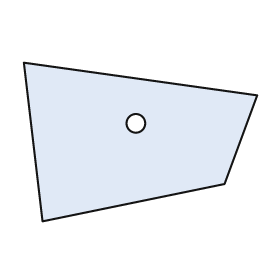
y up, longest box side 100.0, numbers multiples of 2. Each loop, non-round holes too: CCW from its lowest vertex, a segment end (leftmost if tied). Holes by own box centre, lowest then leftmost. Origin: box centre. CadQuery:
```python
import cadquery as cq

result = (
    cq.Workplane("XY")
    .moveTo(-42.0, -34.0)
    .lineTo(36.0, -18.0)
    .lineTo(50.0, 20.0)
    .lineTo(-50.0, 34.0)
    .close()
    .moveTo(-2.0, 8.0)
    .circle(4.0)
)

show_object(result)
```